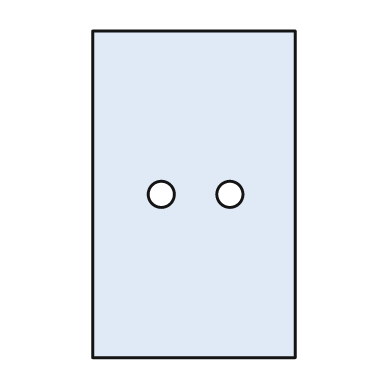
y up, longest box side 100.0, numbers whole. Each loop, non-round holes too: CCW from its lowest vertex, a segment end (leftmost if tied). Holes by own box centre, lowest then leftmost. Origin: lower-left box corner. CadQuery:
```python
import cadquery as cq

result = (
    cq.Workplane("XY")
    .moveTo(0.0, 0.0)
    .lineTo(62.0, 0.0)
    .lineTo(62.0, 100.0)
    .lineTo(0.0, 100.0)
    .close()
    .moveTo(21.0, 50.0)
    .circle(4.0)
    .moveTo(42.0, 50.0)
    .circle(4.0)
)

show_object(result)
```